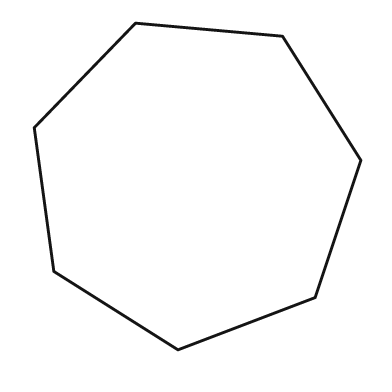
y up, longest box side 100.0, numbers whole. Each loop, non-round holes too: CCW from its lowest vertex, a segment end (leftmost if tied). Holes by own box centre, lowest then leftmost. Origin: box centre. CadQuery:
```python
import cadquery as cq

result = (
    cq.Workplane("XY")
    .moveTo(-6.0, -50.0)
    .lineTo(36.0, -34.0)
    .lineTo(50.0, 8.0)
    .lineTo(26.0, 46.0)
    .lineTo(-19.0, 50.0)
    .lineTo(-50.0, 18.0)
    .lineTo(-44.0, -26.0)
    .close()
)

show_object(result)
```